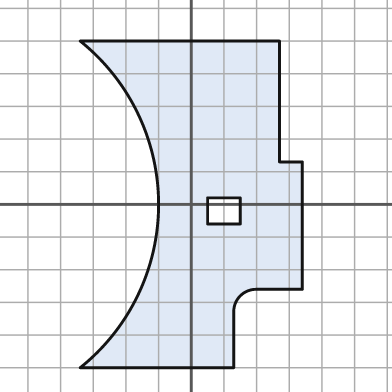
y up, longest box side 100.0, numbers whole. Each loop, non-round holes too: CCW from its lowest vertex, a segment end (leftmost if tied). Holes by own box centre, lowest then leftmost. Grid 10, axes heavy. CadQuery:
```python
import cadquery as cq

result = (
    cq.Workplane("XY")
    .moveTo(-34.0, -50.0)
    .lineTo(13.0, -50.0)
    .lineTo(13.0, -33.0)
    .threePointArc((15.0, -28.0), (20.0, -26.0))
    .lineTo(34.0, -26.0)
    .lineTo(34.0, 13.0)
    .lineTo(27.0, 13.0)
    .lineTo(27.0, 50.0)
    .lineTo(-34.0, 50.0)
    .threePointArc((-10.0, 0.0), (-34.0, -50.0))
    .close()
    .moveTo(5.0, -6.0)
    .lineTo(15.0, -6.0)
    .lineTo(15.0, 2.0)
    .lineTo(5.0, 2.0)
    .close()
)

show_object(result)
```